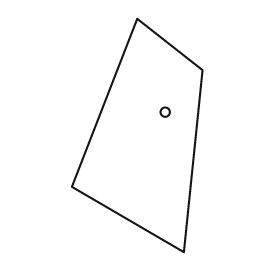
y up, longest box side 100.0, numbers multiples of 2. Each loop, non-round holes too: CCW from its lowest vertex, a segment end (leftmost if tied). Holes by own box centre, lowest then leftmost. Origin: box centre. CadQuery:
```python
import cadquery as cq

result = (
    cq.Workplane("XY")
    .moveTo(20.0, -50.0)
    .lineTo(28.0, 28.0)
    .lineTo(0.0, 50.0)
    .lineTo(-28.0, -22.0)
    .close()
    .moveTo(12.0, 10.0)
    .circle(2.0)
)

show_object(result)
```